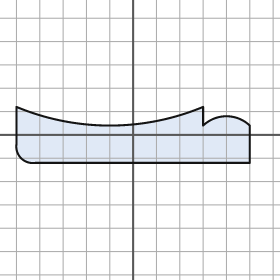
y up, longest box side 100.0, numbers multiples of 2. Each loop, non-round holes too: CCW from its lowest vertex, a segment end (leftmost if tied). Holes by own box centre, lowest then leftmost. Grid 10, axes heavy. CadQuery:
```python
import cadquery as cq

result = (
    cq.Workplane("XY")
    .moveTo(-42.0, -12.0)
    .lineTo(50.0, -12.0)
    .lineTo(50.0, 4.0)
    .threePointArc((40.0, 8.0), (30.0, 4.0))
    .lineTo(30.0, 12.0)
    .threePointArc((-10.0, 4.0), (-50.0, 12.0))
    .lineTo(-50.0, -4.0)
    .threePointArc((-48.0, -10.0), (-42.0, -12.0))
    .close()
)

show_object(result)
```